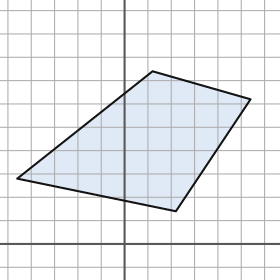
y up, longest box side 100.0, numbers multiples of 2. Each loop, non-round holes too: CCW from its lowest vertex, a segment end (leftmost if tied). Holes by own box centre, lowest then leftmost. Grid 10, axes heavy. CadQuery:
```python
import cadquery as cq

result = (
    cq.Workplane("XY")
    .moveTo(22.0, 14.0)
    .lineTo(54.0, 62.0)
    .lineTo(12.0, 74.0)
    .lineTo(-46.0, 28.0)
    .close()
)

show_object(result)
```